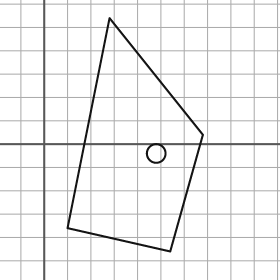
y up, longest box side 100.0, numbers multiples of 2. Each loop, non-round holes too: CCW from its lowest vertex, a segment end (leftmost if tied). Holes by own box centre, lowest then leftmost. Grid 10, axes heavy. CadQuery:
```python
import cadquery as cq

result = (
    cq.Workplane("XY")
    .moveTo(54.0, -46.0)
    .lineTo(68.0, 4.0)
    .lineTo(28.0, 54.0)
    .lineTo(10.0, -36.0)
    .close()
    .moveTo(48.0, -4.0)
    .circle(4.0)
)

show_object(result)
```